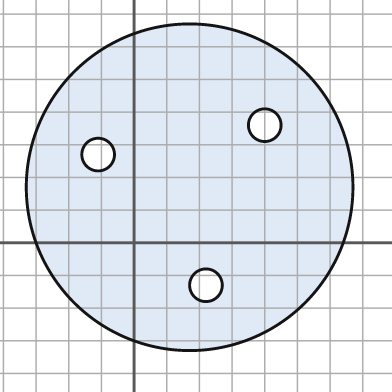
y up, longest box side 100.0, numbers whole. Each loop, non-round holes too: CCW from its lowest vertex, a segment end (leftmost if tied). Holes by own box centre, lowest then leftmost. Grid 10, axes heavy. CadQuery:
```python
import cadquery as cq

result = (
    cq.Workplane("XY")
    .moveTo(17.0, 17.0)
    .circle(50.0)
    .moveTo(22.0, -13.0)
    .circle(5.0)
    .moveTo(-11.0, 27.0)
    .circle(5.0)
    .moveTo(40.0, 36.0)
    .circle(5.0)
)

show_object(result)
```